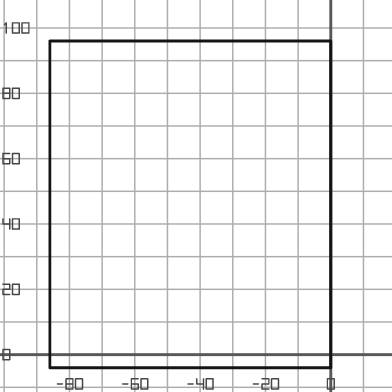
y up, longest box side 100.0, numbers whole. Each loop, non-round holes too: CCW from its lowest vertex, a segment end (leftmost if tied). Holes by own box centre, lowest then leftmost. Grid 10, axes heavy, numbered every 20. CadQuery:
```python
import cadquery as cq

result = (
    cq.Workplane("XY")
    .moveTo(-86.0, -4.0)
    .lineTo(0.0, -4.0)
    .lineTo(0.0, 96.0)
    .lineTo(-86.0, 96.0)
    .close()
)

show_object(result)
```